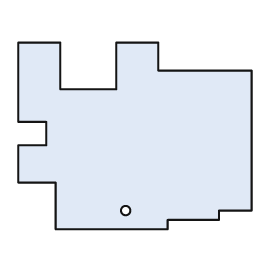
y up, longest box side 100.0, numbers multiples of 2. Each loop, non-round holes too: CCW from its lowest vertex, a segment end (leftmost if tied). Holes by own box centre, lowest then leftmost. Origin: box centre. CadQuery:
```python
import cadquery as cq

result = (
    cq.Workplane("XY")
    .moveTo(-34.0, -40.0)
    .lineTo(14.0, -40.0)
    .lineTo(14.0, -36.0)
    .lineTo(36.0, -36.0)
    .lineTo(36.0, -32.0)
    .lineTo(50.0, -32.0)
    .lineTo(50.0, 28.0)
    .lineTo(10.0, 28.0)
    .lineTo(10.0, 40.0)
    .lineTo(-8.0, 40.0)
    .lineTo(-8.0, 20.0)
    .lineTo(-32.0, 20.0)
    .lineTo(-32.0, 40.0)
    .lineTo(-50.0, 40.0)
    .lineTo(-50.0, 6.0)
    .lineTo(-38.0, 6.0)
    .lineTo(-38.0, -4.0)
    .lineTo(-50.0, -4.0)
    .lineTo(-50.0, -20.0)
    .lineTo(-34.0, -20.0)
    .close()
    .moveTo(-4.0, -32.0)
    .circle(2.0)
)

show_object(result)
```